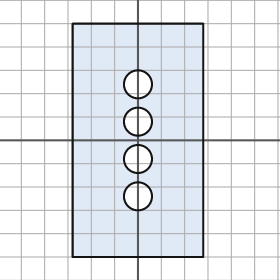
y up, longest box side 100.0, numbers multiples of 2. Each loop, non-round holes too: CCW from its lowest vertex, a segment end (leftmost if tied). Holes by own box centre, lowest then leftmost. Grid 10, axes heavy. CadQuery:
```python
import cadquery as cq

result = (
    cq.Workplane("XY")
    .moveTo(-28.0, -50.0)
    .lineTo(28.0, -50.0)
    .lineTo(28.0, 50.0)
    .lineTo(-28.0, 50.0)
    .close()
    .moveTo(0.0, -24.0)
    .circle(6.0)
    .moveTo(0.0, -8.0)
    .circle(6.0)
    .moveTo(0.0, 8.0)
    .circle(6.0)
    .moveTo(0.0, 24.0)
    .circle(6.0)
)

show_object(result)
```